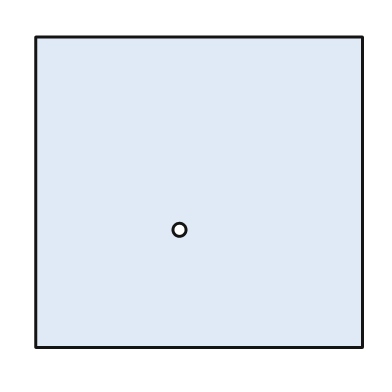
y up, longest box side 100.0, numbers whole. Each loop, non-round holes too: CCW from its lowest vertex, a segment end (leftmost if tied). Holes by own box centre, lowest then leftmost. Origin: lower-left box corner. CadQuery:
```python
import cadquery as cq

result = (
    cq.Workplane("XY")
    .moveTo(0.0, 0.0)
    .lineTo(100.0, 0.0)
    .lineTo(100.0, 95.0)
    .lineTo(0.0, 95.0)
    .close()
    .moveTo(44.0, 36.0)
    .circle(2.0)
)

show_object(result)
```